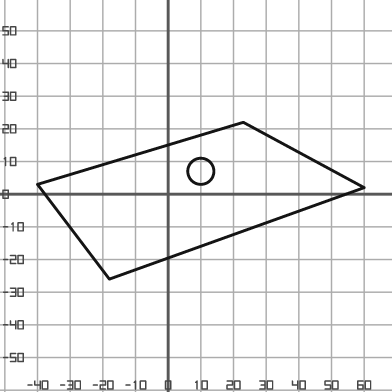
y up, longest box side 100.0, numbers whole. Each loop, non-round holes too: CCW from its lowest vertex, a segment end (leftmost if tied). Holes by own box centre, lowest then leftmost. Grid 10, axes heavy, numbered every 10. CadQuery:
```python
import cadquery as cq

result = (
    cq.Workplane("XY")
    .moveTo(-18.0, -26.0)
    .lineTo(60.0, 2.0)
    .lineTo(23.0, 22.0)
    .lineTo(-40.0, 3.0)
    .close()
    .moveTo(10.0, 7.0)
    .circle(4.0)
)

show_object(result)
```